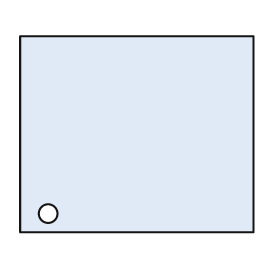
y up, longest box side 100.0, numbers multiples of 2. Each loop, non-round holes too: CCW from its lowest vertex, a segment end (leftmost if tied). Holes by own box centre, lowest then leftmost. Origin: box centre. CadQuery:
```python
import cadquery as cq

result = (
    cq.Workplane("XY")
    .moveTo(-50.0, -42.0)
    .lineTo(50.0, -42.0)
    .lineTo(50.0, 42.0)
    .lineTo(-50.0, 42.0)
    .close()
    .moveTo(-38.0, -34.0)
    .circle(4.0)
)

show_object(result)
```